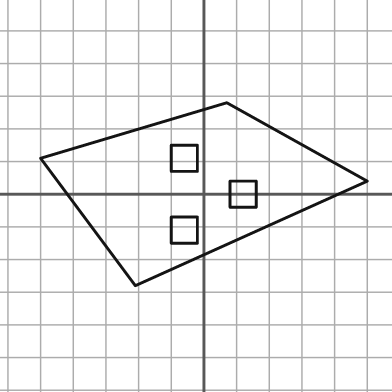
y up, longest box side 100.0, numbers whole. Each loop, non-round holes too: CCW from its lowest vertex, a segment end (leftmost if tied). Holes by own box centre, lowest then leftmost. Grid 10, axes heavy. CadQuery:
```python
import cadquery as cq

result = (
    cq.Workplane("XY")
    .moveTo(-21.0, -28.0)
    .lineTo(50.0, 4.0)
    .lineTo(7.0, 28.0)
    .lineTo(-50.0, 11.0)
    .close()
    .moveTo(-10.0, -15.0)
    .lineTo(-2.0, -15.0)
    .lineTo(-2.0, -7.0)
    .lineTo(-10.0, -7.0)
    .close()
    .moveTo(8.0, -4.0)
    .lineTo(16.0, -4.0)
    .lineTo(16.0, 4.0)
    .lineTo(8.0, 4.0)
    .close()
    .moveTo(-10.0, 7.0)
    .lineTo(-2.0, 7.0)
    .lineTo(-2.0, 15.0)
    .lineTo(-10.0, 15.0)
    .close()
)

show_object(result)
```